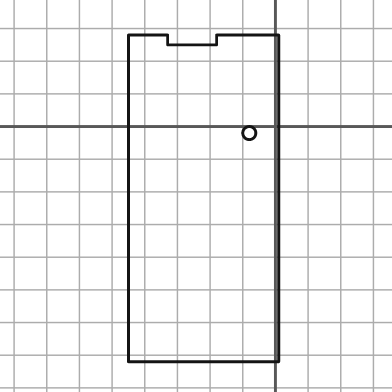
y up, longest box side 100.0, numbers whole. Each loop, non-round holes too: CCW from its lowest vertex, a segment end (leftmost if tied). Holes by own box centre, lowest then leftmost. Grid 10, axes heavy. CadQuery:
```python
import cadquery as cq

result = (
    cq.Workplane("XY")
    .moveTo(-45.0, -72.0)
    .lineTo(1.0, -72.0)
    .lineTo(1.0, 28.0)
    .lineTo(-18.0, 28.0)
    .lineTo(-18.0, 25.0)
    .lineTo(-33.0, 25.0)
    .lineTo(-33.0, 28.0)
    .lineTo(-45.0, 28.0)
    .close()
    .moveTo(-8.0, -2.0)
    .circle(2.0)
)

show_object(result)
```